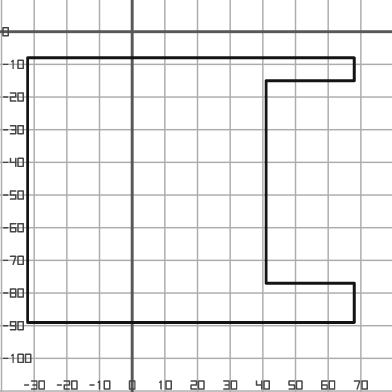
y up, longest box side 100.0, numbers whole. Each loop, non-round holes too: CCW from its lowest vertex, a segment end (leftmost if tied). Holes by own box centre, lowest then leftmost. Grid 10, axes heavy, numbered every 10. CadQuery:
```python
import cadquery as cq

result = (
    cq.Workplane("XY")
    .moveTo(-32.0, -89.0)
    .lineTo(68.0, -89.0)
    .lineTo(68.0, -77.0)
    .lineTo(41.0, -77.0)
    .lineTo(41.0, -15.0)
    .lineTo(68.0, -15.0)
    .lineTo(68.0, -8.0)
    .lineTo(-32.0, -8.0)
    .close()
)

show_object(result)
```